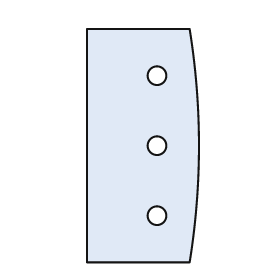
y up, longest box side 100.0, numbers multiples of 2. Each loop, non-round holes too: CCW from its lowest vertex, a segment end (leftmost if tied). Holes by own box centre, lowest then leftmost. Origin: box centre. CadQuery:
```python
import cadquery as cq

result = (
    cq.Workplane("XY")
    .moveTo(-24.0, -50.0)
    .lineTo(20.0, -50.0)
    .threePointArc((24.0, 0.0), (20.0, 50.0))
    .lineTo(-24.0, 50.0)
    .close()
    .moveTo(6.0, -30.0)
    .circle(4.0)
    .moveTo(6.0, 0.0)
    .circle(4.0)
    .moveTo(6.0, 30.0)
    .circle(4.0)
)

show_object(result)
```